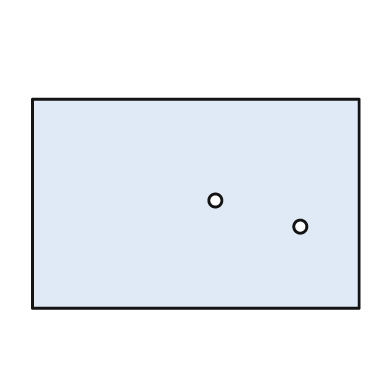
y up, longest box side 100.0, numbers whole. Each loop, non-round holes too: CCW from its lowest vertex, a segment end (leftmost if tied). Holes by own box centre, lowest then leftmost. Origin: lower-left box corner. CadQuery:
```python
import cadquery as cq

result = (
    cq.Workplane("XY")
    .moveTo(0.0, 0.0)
    .lineTo(100.0, 0.0)
    .lineTo(100.0, 64.0)
    .lineTo(0.0, 64.0)
    .close()
    .moveTo(82.0, 25.0)
    .circle(2.0)
    .moveTo(56.0, 33.0)
    .circle(2.0)
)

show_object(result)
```